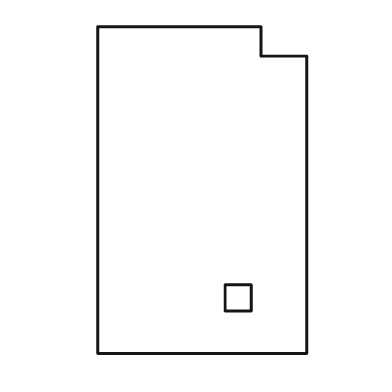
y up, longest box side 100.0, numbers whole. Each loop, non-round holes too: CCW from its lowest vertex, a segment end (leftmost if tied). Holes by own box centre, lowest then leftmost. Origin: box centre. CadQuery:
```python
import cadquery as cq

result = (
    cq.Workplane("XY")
    .moveTo(-32.0, -50.0)
    .lineTo(32.0, -50.0)
    .lineTo(32.0, 41.0)
    .lineTo(18.0, 41.0)
    .lineTo(18.0, 50.0)
    .lineTo(-32.0, 50.0)
    .close()
    .moveTo(7.0, -37.0)
    .lineTo(15.0, -37.0)
    .lineTo(15.0, -29.0)
    .lineTo(7.0, -29.0)
    .close()
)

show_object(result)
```